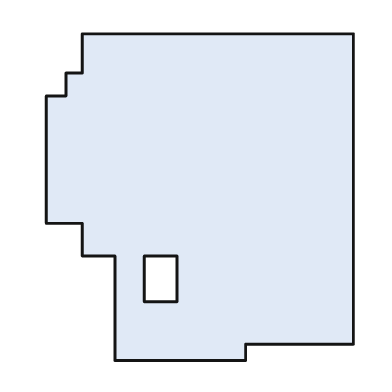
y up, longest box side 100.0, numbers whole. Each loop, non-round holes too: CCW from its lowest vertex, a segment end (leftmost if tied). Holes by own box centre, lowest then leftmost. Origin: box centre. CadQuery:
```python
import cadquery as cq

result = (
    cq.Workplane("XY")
    .moveTo(-26.0, -50.0)
    .lineTo(14.0, -50.0)
    .lineTo(14.0, -45.0)
    .lineTo(47.0, -45.0)
    .lineTo(47.0, 50.0)
    .lineTo(-36.0, 50.0)
    .lineTo(-36.0, 38.0)
    .lineTo(-41.0, 38.0)
    .lineTo(-41.0, 31.0)
    .lineTo(-47.0, 31.0)
    .lineTo(-47.0, -8.0)
    .lineTo(-36.0, -8.0)
    .lineTo(-36.0, -18.0)
    .lineTo(-26.0, -18.0)
    .close()
    .moveTo(-17.0, -32.0)
    .lineTo(-7.0, -32.0)
    .lineTo(-7.0, -18.0)
    .lineTo(-17.0, -18.0)
    .close()
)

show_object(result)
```